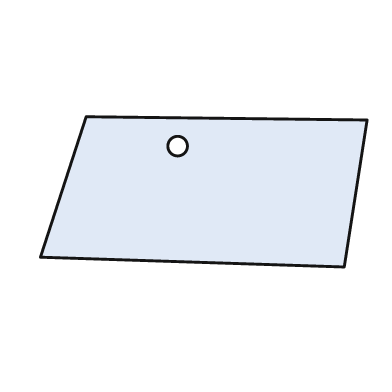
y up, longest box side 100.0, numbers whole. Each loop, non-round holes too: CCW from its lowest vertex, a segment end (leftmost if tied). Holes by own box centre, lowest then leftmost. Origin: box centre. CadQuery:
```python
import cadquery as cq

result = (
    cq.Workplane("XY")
    .moveTo(43.0, -23.0)
    .lineTo(50.0, 22.0)
    .lineTo(-36.0, 23.0)
    .lineTo(-50.0, -20.0)
    .close()
    .moveTo(-8.0, 14.0)
    .circle(3.0)
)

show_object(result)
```